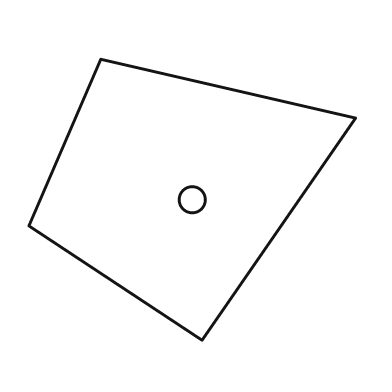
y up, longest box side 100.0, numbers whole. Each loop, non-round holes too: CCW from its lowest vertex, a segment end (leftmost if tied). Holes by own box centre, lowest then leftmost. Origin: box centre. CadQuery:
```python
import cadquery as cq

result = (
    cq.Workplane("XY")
    .moveTo(3.0, -43.0)
    .lineTo(50.0, 25.0)
    .lineTo(-28.0, 43.0)
    .lineTo(-50.0, -8.0)
    .close()
    .moveTo(0.0, 0.0)
    .circle(4.0)
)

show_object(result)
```